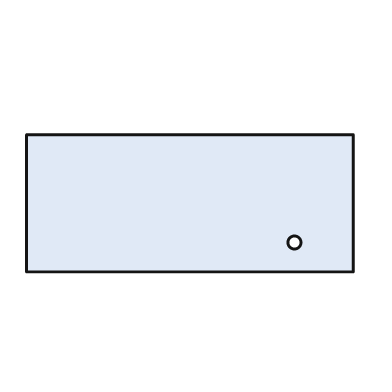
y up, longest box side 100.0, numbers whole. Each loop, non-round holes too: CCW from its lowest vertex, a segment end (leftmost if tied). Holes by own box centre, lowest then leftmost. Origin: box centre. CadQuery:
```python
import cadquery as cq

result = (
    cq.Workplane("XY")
    .moveTo(-50.0, -21.0)
    .lineTo(50.0, -21.0)
    .lineTo(50.0, 21.0)
    .lineTo(-50.0, 21.0)
    .close()
    .moveTo(32.0, -12.0)
    .circle(2.0)
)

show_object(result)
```